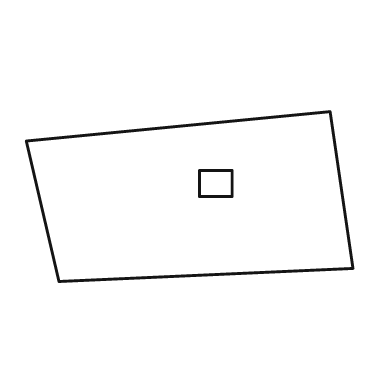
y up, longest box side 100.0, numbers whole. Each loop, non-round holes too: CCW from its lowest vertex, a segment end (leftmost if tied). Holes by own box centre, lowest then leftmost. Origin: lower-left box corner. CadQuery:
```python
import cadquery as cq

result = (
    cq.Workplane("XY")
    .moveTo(10.0, 0.0)
    .lineTo(100.0, 4.0)
    .lineTo(93.0, 52.0)
    .lineTo(0.0, 43.0)
    .close()
    .moveTo(53.0, 26.0)
    .lineTo(63.0, 26.0)
    .lineTo(63.0, 34.0)
    .lineTo(53.0, 34.0)
    .close()
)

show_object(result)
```